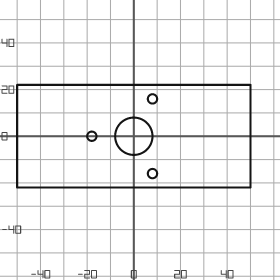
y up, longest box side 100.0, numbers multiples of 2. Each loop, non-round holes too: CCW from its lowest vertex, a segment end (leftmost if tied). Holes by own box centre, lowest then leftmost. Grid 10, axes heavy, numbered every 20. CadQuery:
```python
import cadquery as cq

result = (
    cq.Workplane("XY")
    .moveTo(-50.0, -22.0)
    .lineTo(50.0, -22.0)
    .lineTo(50.0, 22.0)
    .lineTo(-50.0, 22.0)
    .close()
    .moveTo(8.0, -16.0)
    .circle(2.0)
    .moveTo(-18.0, 0.0)
    .circle(2.0)
    .moveTo(0.0, 0.0)
    .circle(8.0)
    .moveTo(8.0, 16.0)
    .circle(2.0)
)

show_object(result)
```